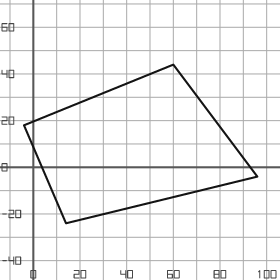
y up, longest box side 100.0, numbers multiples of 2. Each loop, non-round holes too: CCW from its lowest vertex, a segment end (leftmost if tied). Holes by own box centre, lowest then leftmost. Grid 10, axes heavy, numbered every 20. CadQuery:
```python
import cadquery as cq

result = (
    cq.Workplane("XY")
    .moveTo(14.0, -24.0)
    .lineTo(96.0, -4.0)
    .lineTo(60.0, 44.0)
    .lineTo(-4.0, 18.0)
    .close()
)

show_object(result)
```